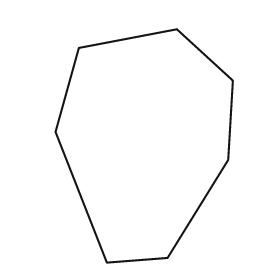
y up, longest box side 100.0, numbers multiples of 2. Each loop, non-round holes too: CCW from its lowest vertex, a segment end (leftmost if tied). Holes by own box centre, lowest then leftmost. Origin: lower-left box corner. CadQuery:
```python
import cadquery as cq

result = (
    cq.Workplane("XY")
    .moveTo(22.0, 0.0)
    .lineTo(48.0, 2.0)
    .lineTo(74.0, 44.0)
    .lineTo(76.0, 78.0)
    .lineTo(52.0, 100.0)
    .lineTo(10.0, 92.0)
    .lineTo(0.0, 56.0)
    .close()
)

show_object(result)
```